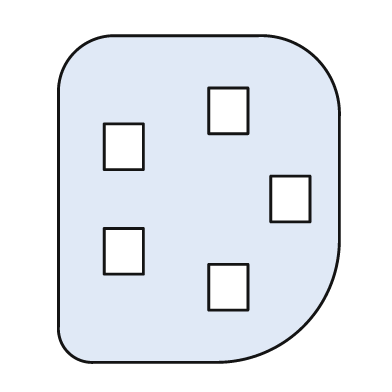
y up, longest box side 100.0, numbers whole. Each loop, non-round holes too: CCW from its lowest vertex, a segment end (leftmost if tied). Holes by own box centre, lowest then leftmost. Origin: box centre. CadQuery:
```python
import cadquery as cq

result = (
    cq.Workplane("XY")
    .moveTo(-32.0, -50.0)
    .lineTo(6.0, -50.0)
    .threePointArc((32.0, -39.0), (43.0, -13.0))
    .lineTo(43.0, 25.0)
    .threePointArc((36.0, 43.0), (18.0, 50.0))
    .lineTo(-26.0, 50.0)
    .threePointArc((-38.0, 45.0), (-43.0, 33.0))
    .lineTo(-43.0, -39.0)
    .threePointArc((-40.0, -47.0), (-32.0, -50.0))
    .close()
    .moveTo(3.0, -34.0)
    .lineTo(15.0, -34.0)
    .lineTo(15.0, -20.0)
    .lineTo(3.0, -20.0)
    .close()
    .moveTo(-29.0, -23.0)
    .lineTo(-17.0, -23.0)
    .lineTo(-17.0, -9.0)
    .lineTo(-29.0, -9.0)
    .close()
    .moveTo(22.0, -7.0)
    .lineTo(34.0, -7.0)
    .lineTo(34.0, 7.0)
    .lineTo(22.0, 7.0)
    .close()
    .moveTo(-29.0, 9.0)
    .lineTo(-17.0, 9.0)
    .lineTo(-17.0, 23.0)
    .lineTo(-29.0, 23.0)
    .close()
    .moveTo(3.0, 20.0)
    .lineTo(15.0, 20.0)
    .lineTo(15.0, 34.0)
    .lineTo(3.0, 34.0)
    .close()
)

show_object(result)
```